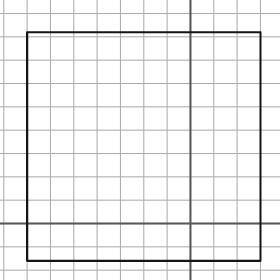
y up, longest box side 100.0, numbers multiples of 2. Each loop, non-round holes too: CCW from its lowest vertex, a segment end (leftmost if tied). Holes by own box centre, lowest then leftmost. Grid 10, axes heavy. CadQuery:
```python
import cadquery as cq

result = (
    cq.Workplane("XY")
    .moveTo(-70.0, -16.0)
    .lineTo(30.0, -16.0)
    .lineTo(30.0, 82.0)
    .lineTo(-70.0, 82.0)
    .close()
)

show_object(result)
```